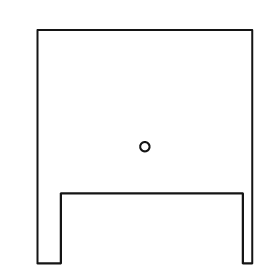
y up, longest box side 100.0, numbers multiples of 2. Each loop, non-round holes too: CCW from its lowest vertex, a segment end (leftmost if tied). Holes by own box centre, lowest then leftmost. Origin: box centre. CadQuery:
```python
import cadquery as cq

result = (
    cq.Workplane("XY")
    .moveTo(-46.0, -50.0)
    .lineTo(-36.0, -50.0)
    .lineTo(-36.0, -20.0)
    .lineTo(42.0, -20.0)
    .lineTo(42.0, -50.0)
    .lineTo(46.0, -50.0)
    .lineTo(46.0, 50.0)
    .lineTo(-46.0, 50.0)
    .close()
    .moveTo(0.0, 0.0)
    .circle(2.0)
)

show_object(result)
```